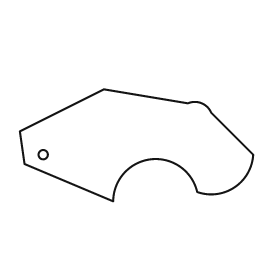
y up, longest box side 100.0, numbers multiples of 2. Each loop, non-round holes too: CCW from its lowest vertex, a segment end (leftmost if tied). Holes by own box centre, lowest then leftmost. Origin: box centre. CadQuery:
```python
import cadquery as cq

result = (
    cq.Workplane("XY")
    .moveTo(-10.0, -24.0)
    .threePointArc((6.0, -6.0), (26.0, -20.0))
    .threePointArc((42.0, -18.0), (50.0, -4.0))
    .lineTo(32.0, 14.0)
    .threePointArc((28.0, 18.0), (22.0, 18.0))
    .lineTo(-14.0, 24.0)
    .lineTo(-50.0, 6.0)
    .lineTo(-48.0, -8.0)
    .close()
    .moveTo(-40.0, -4.0)
    .circle(2.0)
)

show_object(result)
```